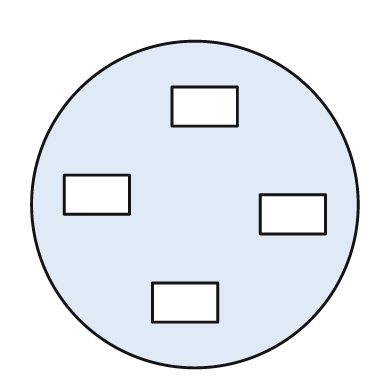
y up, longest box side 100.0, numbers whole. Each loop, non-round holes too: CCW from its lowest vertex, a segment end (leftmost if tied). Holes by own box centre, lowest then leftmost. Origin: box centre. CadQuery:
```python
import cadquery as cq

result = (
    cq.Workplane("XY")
    .moveTo(0.0, 0.0)
    .circle(50.0)
    .moveTo(-13.0, -36.0)
    .lineTo(7.0, -36.0)
    .lineTo(7.0, -24.0)
    .lineTo(-13.0, -24.0)
    .close()
    .moveTo(20.0, -9.0)
    .lineTo(40.0, -9.0)
    .lineTo(40.0, 3.0)
    .lineTo(20.0, 3.0)
    .close()
    .moveTo(-40.0, -3.0)
    .lineTo(-20.0, -3.0)
    .lineTo(-20.0, 9.0)
    .lineTo(-40.0, 9.0)
    .close()
    .moveTo(-7.0, 24.0)
    .lineTo(13.0, 24.0)
    .lineTo(13.0, 36.0)
    .lineTo(-7.0, 36.0)
    .close()
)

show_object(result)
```